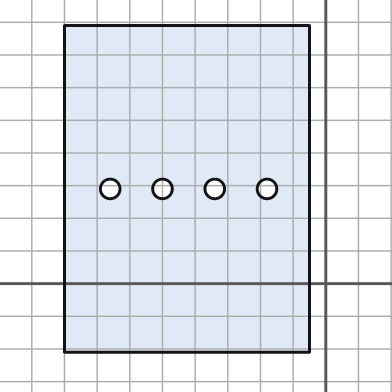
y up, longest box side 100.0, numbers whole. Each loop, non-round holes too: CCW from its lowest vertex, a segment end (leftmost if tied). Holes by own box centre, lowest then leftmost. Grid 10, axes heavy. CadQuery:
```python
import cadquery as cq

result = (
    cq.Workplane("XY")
    .moveTo(-80.0, -21.0)
    .lineTo(-5.0, -21.0)
    .lineTo(-5.0, 79.0)
    .lineTo(-80.0, 79.0)
    .close()
    .moveTo(-66.0, 29.0)
    .circle(3.0)
    .moveTo(-50.0, 29.0)
    .circle(3.0)
    .moveTo(-34.0, 29.0)
    .circle(3.0)
    .moveTo(-18.0, 29.0)
    .circle(3.0)
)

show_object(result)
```